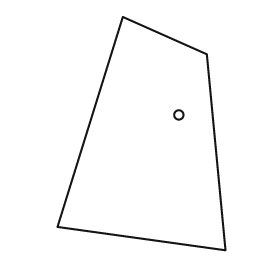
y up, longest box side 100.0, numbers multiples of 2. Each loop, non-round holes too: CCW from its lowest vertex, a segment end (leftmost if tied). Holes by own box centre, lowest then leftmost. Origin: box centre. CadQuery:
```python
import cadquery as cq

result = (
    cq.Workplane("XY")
    .moveTo(36.0, -50.0)
    .lineTo(28.0, 34.0)
    .lineTo(-8.0, 50.0)
    .lineTo(-36.0, -40.0)
    .close()
    .moveTo(16.0, 8.0)
    .circle(2.0)
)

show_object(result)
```